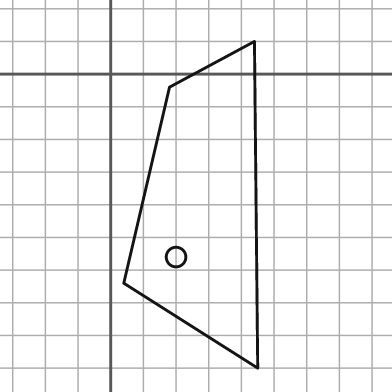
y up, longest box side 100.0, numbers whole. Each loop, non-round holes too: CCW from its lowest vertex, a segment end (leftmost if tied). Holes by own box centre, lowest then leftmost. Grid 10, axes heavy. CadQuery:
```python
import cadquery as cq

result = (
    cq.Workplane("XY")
    .moveTo(45.0, -90.0)
    .lineTo(44.0, 10.0)
    .lineTo(18.0, -4.0)
    .lineTo(4.0, -64.0)
    .close()
    .moveTo(20.0, -56.0)
    .circle(3.0)
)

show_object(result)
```